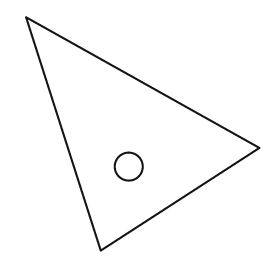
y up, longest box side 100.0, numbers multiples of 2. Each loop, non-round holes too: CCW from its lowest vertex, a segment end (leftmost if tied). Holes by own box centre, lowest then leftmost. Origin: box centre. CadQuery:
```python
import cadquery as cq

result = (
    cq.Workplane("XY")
    .moveTo(-18.0, -50.0)
    .lineTo(50.0, -6.0)
    .lineTo(-50.0, 50.0)
    .close()
    .moveTo(-6.0, -14.0)
    .circle(6.0)
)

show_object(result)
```